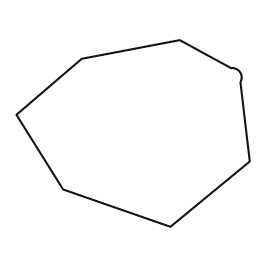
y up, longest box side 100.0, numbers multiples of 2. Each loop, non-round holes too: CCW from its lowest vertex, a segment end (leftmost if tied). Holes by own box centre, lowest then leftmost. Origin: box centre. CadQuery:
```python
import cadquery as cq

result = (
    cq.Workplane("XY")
    .moveTo(16.0, -40.0)
    .lineTo(50.0, -12.0)
    .lineTo(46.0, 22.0)
    .threePointArc((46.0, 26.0), (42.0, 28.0))
    .lineTo(20.0, 40.0)
    .lineTo(-22.0, 32.0)
    .lineTo(-50.0, 8.0)
    .lineTo(-30.0, -24.0)
    .close()
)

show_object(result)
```